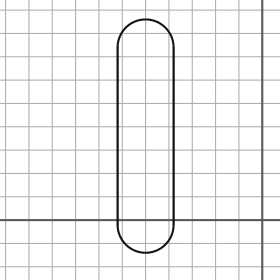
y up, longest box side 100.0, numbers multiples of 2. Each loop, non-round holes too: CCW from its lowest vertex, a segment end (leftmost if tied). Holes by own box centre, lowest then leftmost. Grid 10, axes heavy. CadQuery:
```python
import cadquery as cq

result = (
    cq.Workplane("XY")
    .moveTo(-62.0, -2.0)
    .threePointArc((-50.0, -14.0), (-38.0, -2.0))
    .lineTo(-38.0, 74.0)
    .threePointArc((-50.0, 86.0), (-62.0, 74.0))
    .close()
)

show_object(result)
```